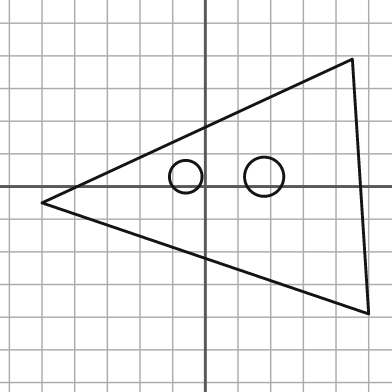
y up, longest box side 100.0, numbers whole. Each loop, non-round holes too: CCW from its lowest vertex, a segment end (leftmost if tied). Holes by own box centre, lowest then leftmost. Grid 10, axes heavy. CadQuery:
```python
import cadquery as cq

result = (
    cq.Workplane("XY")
    .moveTo(50.0, -39.0)
    .lineTo(45.0, 39.0)
    .lineTo(-50.0, -5.0)
    .close()
    .moveTo(-6.0, 3.0)
    .circle(5.0)
    .moveTo(18.0, 3.0)
    .circle(6.0)
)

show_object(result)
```